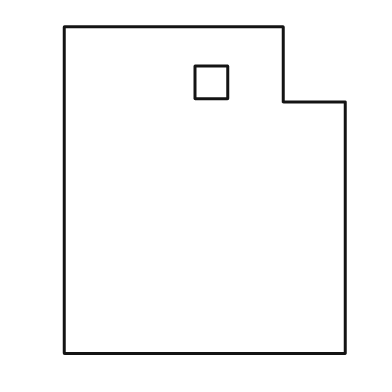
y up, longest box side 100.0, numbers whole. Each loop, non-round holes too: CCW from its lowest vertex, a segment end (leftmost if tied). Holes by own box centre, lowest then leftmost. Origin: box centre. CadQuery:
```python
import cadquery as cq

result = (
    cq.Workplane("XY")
    .moveTo(-43.0, -50.0)
    .lineTo(43.0, -50.0)
    .lineTo(43.0, 27.0)
    .lineTo(24.0, 27.0)
    .lineTo(24.0, 50.0)
    .lineTo(-43.0, 50.0)
    .close()
    .moveTo(-3.0, 28.0)
    .lineTo(7.0, 28.0)
    .lineTo(7.0, 38.0)
    .lineTo(-3.0, 38.0)
    .close()
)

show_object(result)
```